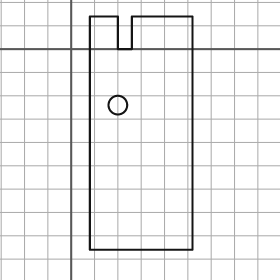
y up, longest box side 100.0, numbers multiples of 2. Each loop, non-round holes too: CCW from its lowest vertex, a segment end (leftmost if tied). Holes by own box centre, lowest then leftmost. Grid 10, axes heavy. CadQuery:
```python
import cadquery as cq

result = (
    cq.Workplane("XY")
    .moveTo(8.0, -86.0)
    .lineTo(52.0, -86.0)
    .lineTo(52.0, 14.0)
    .lineTo(26.0, 14.0)
    .lineTo(26.0, 0.0)
    .lineTo(20.0, 0.0)
    .lineTo(20.0, 14.0)
    .lineTo(8.0, 14.0)
    .close()
    .moveTo(20.0, -24.0)
    .circle(4.0)
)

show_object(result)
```